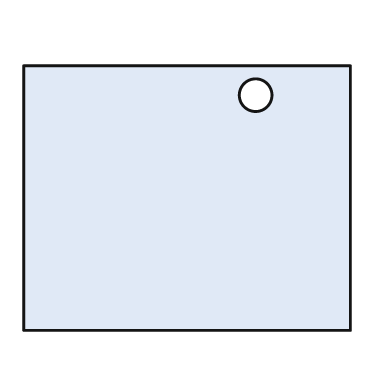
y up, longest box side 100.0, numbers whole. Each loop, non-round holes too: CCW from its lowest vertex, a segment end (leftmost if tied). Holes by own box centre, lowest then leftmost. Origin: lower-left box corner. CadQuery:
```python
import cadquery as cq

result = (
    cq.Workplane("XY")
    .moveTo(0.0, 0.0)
    .lineTo(100.0, 0.0)
    .lineTo(100.0, 81.0)
    .lineTo(0.0, 81.0)
    .close()
    .moveTo(71.0, 72.0)
    .circle(5.0)
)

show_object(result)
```